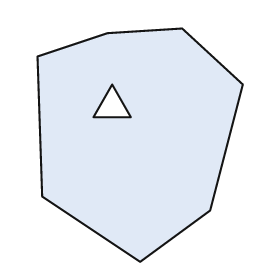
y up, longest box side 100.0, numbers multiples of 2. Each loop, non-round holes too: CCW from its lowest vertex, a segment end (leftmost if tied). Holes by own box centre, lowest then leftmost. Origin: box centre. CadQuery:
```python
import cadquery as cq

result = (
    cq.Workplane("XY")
    .moveTo(0.0, -50.0)
    .lineTo(30.0, -28.0)
    .lineTo(44.0, 26.0)
    .lineTo(18.0, 50.0)
    .lineTo(-14.0, 48.0)
    .lineTo(-44.0, 38.0)
    .lineTo(-42.0, -22.0)
    .close()
    .moveTo(-20.0, 12.0)
    .lineTo(-4.0, 12.0)
    .lineTo(-12.0, 26.0)
    .close()
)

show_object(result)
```